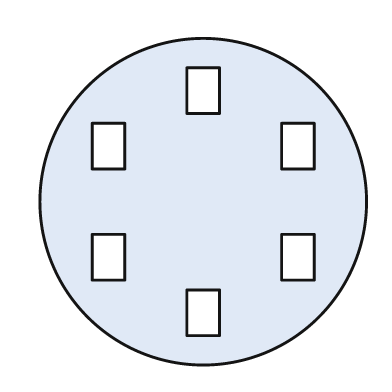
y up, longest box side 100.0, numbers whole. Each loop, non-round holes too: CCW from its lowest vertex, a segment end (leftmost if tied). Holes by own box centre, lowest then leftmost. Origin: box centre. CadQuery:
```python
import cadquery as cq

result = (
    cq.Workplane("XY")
    .moveTo(0.0, 0.0)
    .circle(50.0)
    .moveTo(-5.0, -41.0)
    .lineTo(5.0, -41.0)
    .lineTo(5.0, -27.0)
    .lineTo(-5.0, -27.0)
    .close()
    .moveTo(-34.0, -24.0)
    .lineTo(-24.0, -24.0)
    .lineTo(-24.0, -10.0)
    .lineTo(-34.0, -10.0)
    .close()
    .moveTo(24.0, -24.0)
    .lineTo(34.0, -24.0)
    .lineTo(34.0, -10.0)
    .lineTo(24.0, -10.0)
    .close()
    .moveTo(-34.0, 10.0)
    .lineTo(-24.0, 10.0)
    .lineTo(-24.0, 24.0)
    .lineTo(-34.0, 24.0)
    .close()
    .moveTo(24.0, 10.0)
    .lineTo(34.0, 10.0)
    .lineTo(34.0, 24.0)
    .lineTo(24.0, 24.0)
    .close()
    .moveTo(-5.0, 27.0)
    .lineTo(5.0, 27.0)
    .lineTo(5.0, 41.0)
    .lineTo(-5.0, 41.0)
    .close()
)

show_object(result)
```